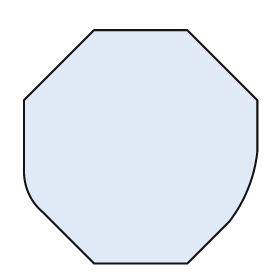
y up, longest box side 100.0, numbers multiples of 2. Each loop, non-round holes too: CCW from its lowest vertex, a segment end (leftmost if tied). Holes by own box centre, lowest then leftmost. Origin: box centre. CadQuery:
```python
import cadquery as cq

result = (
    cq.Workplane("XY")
    .moveTo(-20.0, -50.0)
    .lineTo(20.0, -50.0)
    .lineTo(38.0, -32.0)
    .threePointArc((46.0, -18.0), (50.0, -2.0))
    .lineTo(50.0, 20.0)
    .lineTo(20.0, 50.0)
    .lineTo(-20.0, 50.0)
    .lineTo(-50.0, 20.0)
    .lineTo(-50.0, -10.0)
    .threePointArc((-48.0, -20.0), (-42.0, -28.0))
    .close()
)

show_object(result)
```